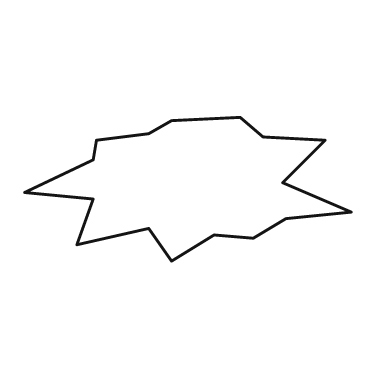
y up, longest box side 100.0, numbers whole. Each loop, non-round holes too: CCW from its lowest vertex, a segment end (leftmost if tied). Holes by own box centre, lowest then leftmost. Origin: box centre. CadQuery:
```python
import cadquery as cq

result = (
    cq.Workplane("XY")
    .moveTo(-5.0, -22.0)
    .lineTo(8.0, -14.0)
    .lineTo(20.0, -15.0)
    .lineTo(30.0, -9.0)
    .lineTo(50.0, -7.0)
    .lineTo(29.0, 2.0)
    .lineTo(42.0, 15.0)
    .lineTo(23.0, 16.0)
    .lineTo(16.0, 22.0)
    .lineTo(-5.0, 21.0)
    .lineTo(-12.0, 17.0)
    .lineTo(-28.0, 15.0)
    .lineTo(-29.0, 9.0)
    .lineTo(-50.0, -1.0)
    .lineTo(-29.0, -3.0)
    .lineTo(-34.0, -17.0)
    .lineTo(-12.0, -12.0)
    .close()
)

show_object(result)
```